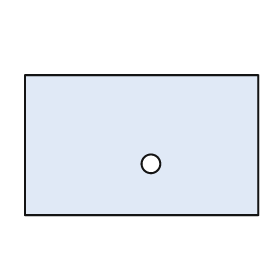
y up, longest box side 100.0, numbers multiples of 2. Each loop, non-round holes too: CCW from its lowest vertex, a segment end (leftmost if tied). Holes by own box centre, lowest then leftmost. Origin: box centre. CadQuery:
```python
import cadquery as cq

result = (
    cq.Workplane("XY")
    .moveTo(-50.0, -30.0)
    .lineTo(50.0, -30.0)
    .lineTo(50.0, 30.0)
    .lineTo(-50.0, 30.0)
    .close()
    .moveTo(4.0, -8.0)
    .circle(4.0)
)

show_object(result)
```